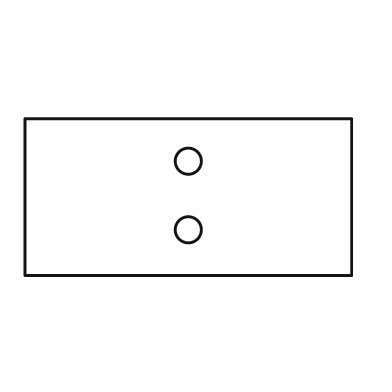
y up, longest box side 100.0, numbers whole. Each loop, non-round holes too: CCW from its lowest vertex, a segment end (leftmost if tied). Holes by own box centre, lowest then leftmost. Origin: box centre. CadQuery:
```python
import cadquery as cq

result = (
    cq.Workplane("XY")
    .moveTo(-50.0, -24.0)
    .lineTo(50.0, -24.0)
    .lineTo(50.0, 24.0)
    .lineTo(-50.0, 24.0)
    .close()
    .moveTo(0.0, -10.0)
    .circle(4.0)
    .moveTo(0.0, 11.0)
    .circle(4.0)
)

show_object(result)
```